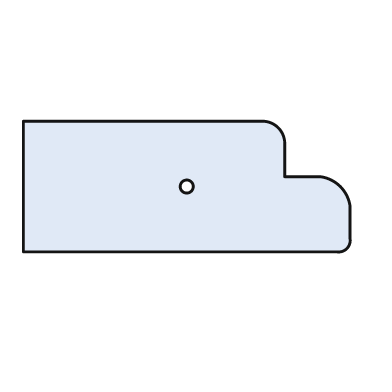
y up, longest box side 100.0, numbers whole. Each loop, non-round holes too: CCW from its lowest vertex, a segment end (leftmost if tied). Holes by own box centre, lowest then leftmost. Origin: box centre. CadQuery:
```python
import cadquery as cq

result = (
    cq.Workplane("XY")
    .moveTo(-50.0, -20.0)
    .lineTo(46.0, -20.0)
    .threePointArc((49.0, -19.0), (50.0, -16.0))
    .lineTo(50.0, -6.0)
    .threePointArc((47.0, 0.0), (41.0, 3.0))
    .lineTo(30.0, 3.0)
    .lineTo(30.0, 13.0)
    .threePointArc((28.0, 18.0), (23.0, 20.0))
    .lineTo(-50.0, 20.0)
    .close()
    .moveTo(0.0, 0.0)
    .circle(2.0)
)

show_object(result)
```